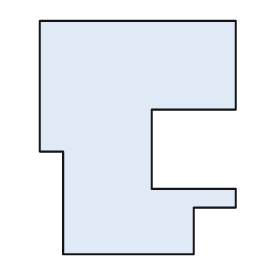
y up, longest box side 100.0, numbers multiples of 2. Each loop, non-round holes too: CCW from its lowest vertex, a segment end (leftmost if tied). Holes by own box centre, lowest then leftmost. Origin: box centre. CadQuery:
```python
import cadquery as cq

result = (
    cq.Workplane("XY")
    .moveTo(-32.0, -50.0)
    .lineTo(24.0, -50.0)
    .lineTo(24.0, -30.0)
    .lineTo(42.0, -30.0)
    .lineTo(42.0, -22.0)
    .lineTo(6.0, -22.0)
    .lineTo(6.0, 12.0)
    .lineTo(42.0, 12.0)
    .lineTo(42.0, 50.0)
    .lineTo(-42.0, 50.0)
    .lineTo(-42.0, -6.0)
    .lineTo(-32.0, -6.0)
    .close()
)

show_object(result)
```